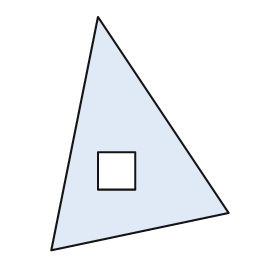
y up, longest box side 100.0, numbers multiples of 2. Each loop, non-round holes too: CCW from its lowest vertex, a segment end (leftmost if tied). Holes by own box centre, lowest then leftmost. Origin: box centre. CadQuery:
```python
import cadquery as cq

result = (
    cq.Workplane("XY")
    .moveTo(-38.0, -50.0)
    .lineTo(38.0, -34.0)
    .lineTo(-18.0, 50.0)
    .close()
    .moveTo(-18.0, -24.0)
    .lineTo(-2.0, -24.0)
    .lineTo(-2.0, -8.0)
    .lineTo(-18.0, -8.0)
    .close()
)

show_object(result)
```